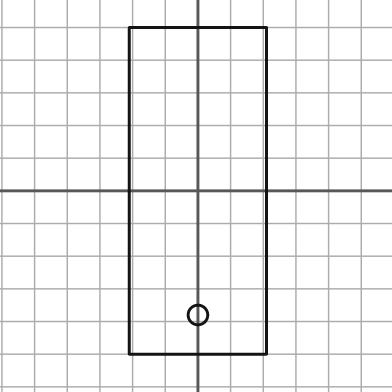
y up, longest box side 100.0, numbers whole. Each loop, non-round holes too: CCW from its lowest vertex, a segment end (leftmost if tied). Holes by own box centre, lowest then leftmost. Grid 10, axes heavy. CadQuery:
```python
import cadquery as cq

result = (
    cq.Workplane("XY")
    .moveTo(-21.0, -50.0)
    .lineTo(21.0, -50.0)
    .lineTo(21.0, 50.0)
    .lineTo(-21.0, 50.0)
    .close()
    .moveTo(0.0, -38.0)
    .circle(3.0)
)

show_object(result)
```